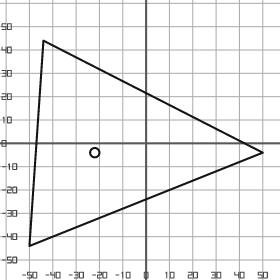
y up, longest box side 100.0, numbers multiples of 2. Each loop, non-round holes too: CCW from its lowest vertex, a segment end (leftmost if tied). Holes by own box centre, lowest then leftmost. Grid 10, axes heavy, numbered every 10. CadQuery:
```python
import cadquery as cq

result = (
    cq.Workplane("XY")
    .moveTo(-50.0, -44.0)
    .lineTo(50.0, -4.0)
    .lineTo(-44.0, 44.0)
    .close()
    .moveTo(-22.0, -4.0)
    .circle(2.0)
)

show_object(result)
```